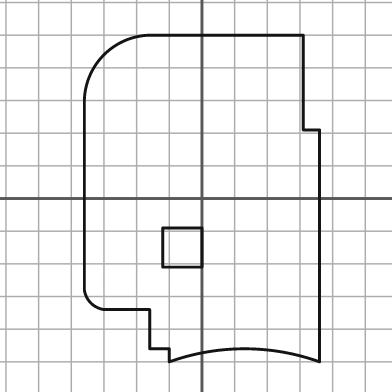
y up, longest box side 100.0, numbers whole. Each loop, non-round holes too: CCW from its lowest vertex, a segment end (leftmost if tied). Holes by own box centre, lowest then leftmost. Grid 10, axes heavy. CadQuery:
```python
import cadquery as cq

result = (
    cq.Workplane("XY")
    .moveTo(-10.0, -50.0)
    .threePointArc((13.0, -46.0), (36.0, -50.0))
    .lineTo(36.0, 21.0)
    .lineTo(31.0, 21.0)
    .lineTo(31.0, 50.0)
    .lineTo(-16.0, 50.0)
    .threePointArc((-30.0, 44.0), (-36.0, 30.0))
    .lineTo(-36.0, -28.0)
    .threePointArc((-34.0, -32.0), (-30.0, -34.0))
    .lineTo(-16.0, -34.0)
    .lineTo(-16.0, -46.0)
    .lineTo(-10.0, -46.0)
    .close()
    .moveTo(-12.0, -21.0)
    .lineTo(0.0, -21.0)
    .lineTo(0.0, -9.0)
    .lineTo(-12.0, -9.0)
    .close()
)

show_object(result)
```